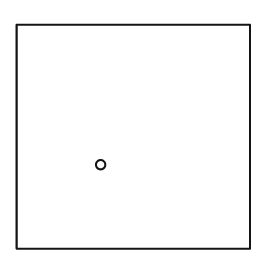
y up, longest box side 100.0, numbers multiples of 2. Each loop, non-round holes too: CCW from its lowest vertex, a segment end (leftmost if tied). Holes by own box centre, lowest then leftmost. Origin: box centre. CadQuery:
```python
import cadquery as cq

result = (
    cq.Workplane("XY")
    .moveTo(-50.0, -48.0)
    .lineTo(50.0, -48.0)
    .lineTo(50.0, 48.0)
    .lineTo(-50.0, 48.0)
    .close()
    .moveTo(-14.0, -12.0)
    .circle(2.0)
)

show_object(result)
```